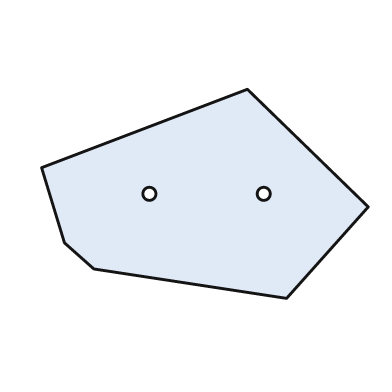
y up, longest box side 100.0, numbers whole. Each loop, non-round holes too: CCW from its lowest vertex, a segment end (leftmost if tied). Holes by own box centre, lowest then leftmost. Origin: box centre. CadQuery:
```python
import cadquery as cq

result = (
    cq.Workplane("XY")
    .moveTo(25.0, -32.0)
    .lineTo(50.0, -4.0)
    .lineTo(13.0, 32.0)
    .lineTo(-50.0, 8.0)
    .lineTo(-43.0, -15.0)
    .lineTo(-34.0, -23.0)
    .close()
    .moveTo(-17.0, 0.0)
    .circle(2.0)
    .moveTo(18.0, 0.0)
    .circle(2.0)
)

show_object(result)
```